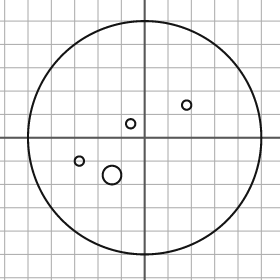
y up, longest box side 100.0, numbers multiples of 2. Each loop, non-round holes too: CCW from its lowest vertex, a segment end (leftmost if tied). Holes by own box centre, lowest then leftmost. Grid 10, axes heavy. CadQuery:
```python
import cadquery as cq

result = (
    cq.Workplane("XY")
    .moveTo(0.0, 0.0)
    .circle(50.0)
    .moveTo(-14.0, -16.0)
    .circle(4.0)
    .moveTo(-28.0, -10.0)
    .circle(2.0)
    .moveTo(-6.0, 6.0)
    .circle(2.0)
    .moveTo(18.0, 14.0)
    .circle(2.0)
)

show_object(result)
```